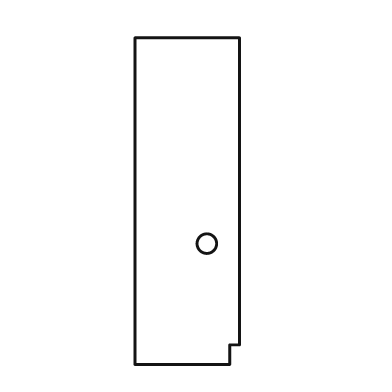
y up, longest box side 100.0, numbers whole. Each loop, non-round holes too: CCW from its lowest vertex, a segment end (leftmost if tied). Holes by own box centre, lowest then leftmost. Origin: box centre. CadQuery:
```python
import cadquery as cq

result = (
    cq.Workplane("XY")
    .moveTo(-16.0, -50.0)
    .lineTo(13.0, -50.0)
    .lineTo(13.0, -44.0)
    .lineTo(16.0, -44.0)
    .lineTo(16.0, 50.0)
    .lineTo(-16.0, 50.0)
    .close()
    .moveTo(6.0, -13.0)
    .circle(3.0)
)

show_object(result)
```